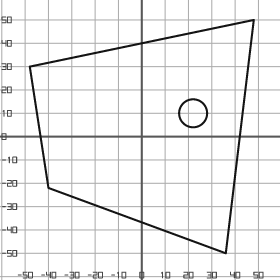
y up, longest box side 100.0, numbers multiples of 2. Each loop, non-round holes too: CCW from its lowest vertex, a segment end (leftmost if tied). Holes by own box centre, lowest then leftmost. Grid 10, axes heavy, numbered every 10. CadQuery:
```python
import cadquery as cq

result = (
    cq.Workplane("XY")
    .moveTo(36.0, -50.0)
    .lineTo(48.0, 50.0)
    .lineTo(-48.0, 30.0)
    .lineTo(-40.0, -22.0)
    .close()
    .moveTo(22.0, 10.0)
    .circle(6.0)
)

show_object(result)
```